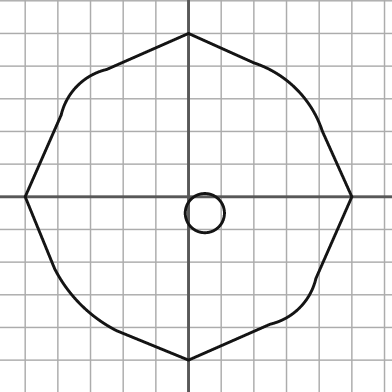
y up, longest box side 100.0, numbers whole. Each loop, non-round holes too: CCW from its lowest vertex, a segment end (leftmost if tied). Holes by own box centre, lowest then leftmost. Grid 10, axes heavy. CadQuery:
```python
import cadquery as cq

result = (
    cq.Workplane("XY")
    .moveTo(0.0, -50.0)
    .lineTo(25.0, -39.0)
    .threePointArc((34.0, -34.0), (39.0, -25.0))
    .lineTo(50.0, 0.0)
    .lineTo(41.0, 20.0)
    .threePointArc((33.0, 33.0), (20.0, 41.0))
    .lineTo(0.0, 50.0)
    .lineTo(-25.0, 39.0)
    .threePointArc((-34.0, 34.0), (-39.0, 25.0))
    .lineTo(-50.0, 0.0)
    .lineTo(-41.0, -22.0)
    .threePointArc((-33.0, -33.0), (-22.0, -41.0))
    .close()
    .moveTo(5.0, -5.0)
    .circle(6.0)
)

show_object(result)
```